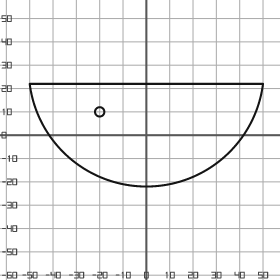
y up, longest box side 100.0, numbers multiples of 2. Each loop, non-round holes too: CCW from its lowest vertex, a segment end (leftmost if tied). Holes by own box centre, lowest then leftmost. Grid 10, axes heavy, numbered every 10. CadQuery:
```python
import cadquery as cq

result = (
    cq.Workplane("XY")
    .moveTo(-50.0, 22.0)
    .threePointArc((0.0, -22.0), (50.0, 22.0))
    .close()
    .moveTo(-20.0, 10.0)
    .circle(2.0)
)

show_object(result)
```